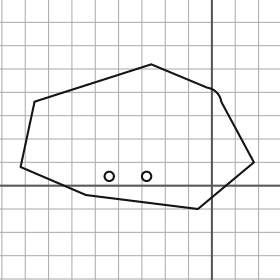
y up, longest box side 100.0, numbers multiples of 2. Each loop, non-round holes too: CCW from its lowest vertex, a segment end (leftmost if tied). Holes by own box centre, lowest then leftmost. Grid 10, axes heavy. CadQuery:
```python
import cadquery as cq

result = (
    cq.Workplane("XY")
    .moveTo(-6.0, -10.0)
    .lineTo(18.0, 10.0)
    .lineTo(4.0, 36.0)
    .threePointArc((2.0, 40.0), (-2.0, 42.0))
    .lineTo(-26.0, 52.0)
    .lineTo(-76.0, 36.0)
    .lineTo(-82.0, 8.0)
    .lineTo(-54.0, -4.0)
    .close()
    .moveTo(-44.0, 4.0)
    .circle(2.0)
    .moveTo(-28.0, 4.0)
    .circle(2.0)
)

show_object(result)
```